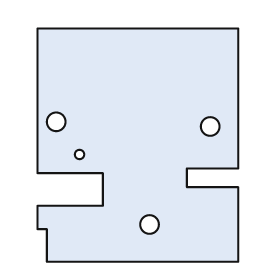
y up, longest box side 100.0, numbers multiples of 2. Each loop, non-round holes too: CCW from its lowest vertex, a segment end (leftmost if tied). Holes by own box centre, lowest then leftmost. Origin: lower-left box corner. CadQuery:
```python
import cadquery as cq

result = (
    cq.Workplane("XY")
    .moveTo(4.0, 0.0)
    .lineTo(86.0, 0.0)
    .lineTo(86.0, 32.0)
    .lineTo(64.0, 32.0)
    .lineTo(64.0, 40.0)
    .lineTo(86.0, 40.0)
    .lineTo(86.0, 100.0)
    .lineTo(0.0, 100.0)
    .lineTo(0.0, 38.0)
    .lineTo(28.0, 38.0)
    .lineTo(28.0, 24.0)
    .lineTo(0.0, 24.0)
    .lineTo(0.0, 14.0)
    .lineTo(4.0, 14.0)
    .close()
    .moveTo(48.0, 16.0)
    .circle(4.0)
    .moveTo(18.0, 46.0)
    .circle(2.0)
    .moveTo(74.0, 58.0)
    .circle(4.0)
    .moveTo(8.0, 60.0)
    .circle(4.0)
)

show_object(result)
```